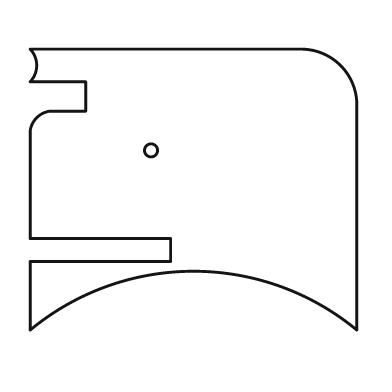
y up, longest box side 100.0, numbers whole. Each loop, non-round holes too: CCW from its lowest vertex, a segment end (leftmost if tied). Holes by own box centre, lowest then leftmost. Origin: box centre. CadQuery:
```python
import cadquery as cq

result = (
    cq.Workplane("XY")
    .moveTo(-50.0, -43.0)
    .threePointArc((0.0, -25.0), (50.0, -43.0))
    .lineTo(50.0, 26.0)
    .threePointArc((45.0, 38.0), (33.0, 43.0))
    .lineTo(-50.0, 43.0)
    .threePointArc((-48.0, 38.0), (-50.0, 33.0))
    .lineTo(-33.0, 33.0)
    .lineTo(-33.0, 24.0)
    .lineTo(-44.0, 24.0)
    .threePointArc((-48.0, 22.0), (-50.0, 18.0))
    .lineTo(-50.0, -15.0)
    .lineTo(-7.0, -15.0)
    .lineTo(-7.0, -22.0)
    .lineTo(-50.0, -22.0)
    .close()
    .moveTo(-13.0, 12.0)
    .circle(2.0)
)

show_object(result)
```